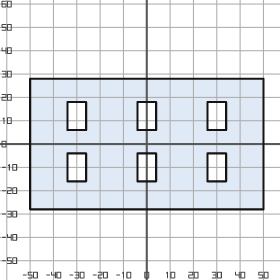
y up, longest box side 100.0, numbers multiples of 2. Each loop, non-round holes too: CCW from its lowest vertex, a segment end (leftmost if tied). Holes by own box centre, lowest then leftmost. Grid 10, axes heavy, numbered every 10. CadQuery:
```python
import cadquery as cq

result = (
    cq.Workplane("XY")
    .moveTo(-50.0, -28.0)
    .lineTo(50.0, -28.0)
    .lineTo(50.0, 28.0)
    .lineTo(-50.0, 28.0)
    .close()
    .moveTo(-34.0, -16.0)
    .lineTo(-26.0, -16.0)
    .lineTo(-26.0, -4.0)
    .lineTo(-34.0, -4.0)
    .close()
    .moveTo(-4.0, -16.0)
    .lineTo(4.0, -16.0)
    .lineTo(4.0, -4.0)
    .lineTo(-4.0, -4.0)
    .close()
    .moveTo(26.0, -16.0)
    .lineTo(34.0, -16.0)
    .lineTo(34.0, -4.0)
    .lineTo(26.0, -4.0)
    .close()
    .moveTo(-34.0, 6.0)
    .lineTo(-26.0, 6.0)
    .lineTo(-26.0, 18.0)
    .lineTo(-34.0, 18.0)
    .close()
    .moveTo(-4.0, 6.0)
    .lineTo(4.0, 6.0)
    .lineTo(4.0, 18.0)
    .lineTo(-4.0, 18.0)
    .close()
    .moveTo(26.0, 6.0)
    .lineTo(34.0, 6.0)
    .lineTo(34.0, 18.0)
    .lineTo(26.0, 18.0)
    .close()
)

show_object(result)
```